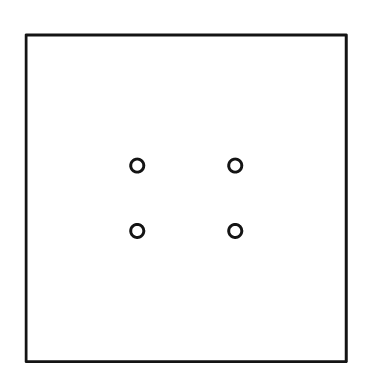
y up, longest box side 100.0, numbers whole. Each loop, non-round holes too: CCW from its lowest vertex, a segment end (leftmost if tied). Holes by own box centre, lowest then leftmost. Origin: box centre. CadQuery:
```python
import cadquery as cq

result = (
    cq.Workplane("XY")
    .moveTo(-49.0, -50.0)
    .lineTo(49.0, -50.0)
    .lineTo(49.0, 50.0)
    .lineTo(-49.0, 50.0)
    .close()
    .moveTo(-15.0, -10.0)
    .circle(2.0)
    .moveTo(15.0, -10.0)
    .circle(2.0)
    .moveTo(-15.0, 10.0)
    .circle(2.0)
    .moveTo(15.0, 10.0)
    .circle(2.0)
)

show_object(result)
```